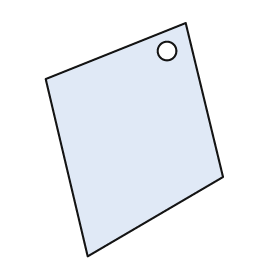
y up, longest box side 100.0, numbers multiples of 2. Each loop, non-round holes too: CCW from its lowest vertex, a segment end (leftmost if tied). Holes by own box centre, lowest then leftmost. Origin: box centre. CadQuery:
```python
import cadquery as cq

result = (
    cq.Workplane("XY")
    .moveTo(-20.0, -50.0)
    .lineTo(38.0, -16.0)
    .lineTo(22.0, 50.0)
    .lineTo(-38.0, 26.0)
    .close()
    .moveTo(14.0, 38.0)
    .circle(4.0)
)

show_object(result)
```